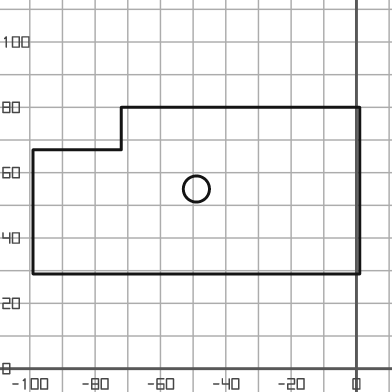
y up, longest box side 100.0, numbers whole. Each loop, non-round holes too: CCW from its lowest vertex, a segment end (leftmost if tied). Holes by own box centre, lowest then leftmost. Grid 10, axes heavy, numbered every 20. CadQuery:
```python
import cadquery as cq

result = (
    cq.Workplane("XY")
    .moveTo(-99.0, 29.0)
    .lineTo(1.0, 29.0)
    .lineTo(1.0, 80.0)
    .lineTo(-72.0, 80.0)
    .lineTo(-72.0, 67.0)
    .lineTo(-99.0, 67.0)
    .close()
    .moveTo(-49.0, 55.0)
    .circle(4.0)
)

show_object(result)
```